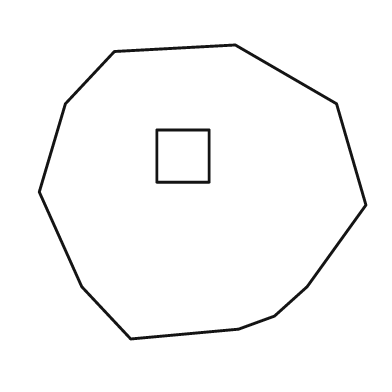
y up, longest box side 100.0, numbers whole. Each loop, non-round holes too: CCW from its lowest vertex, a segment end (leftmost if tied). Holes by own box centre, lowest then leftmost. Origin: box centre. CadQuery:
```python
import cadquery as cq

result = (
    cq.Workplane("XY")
    .moveTo(-22.0, -45.0)
    .lineTo(11.0, -42.0)
    .lineTo(22.0, -38.0)
    .lineTo(32.0, -29.0)
    .lineTo(50.0, -4.0)
    .lineTo(41.0, 27.0)
    .lineTo(10.0, 45.0)
    .lineTo(-27.0, 43.0)
    .lineTo(-42.0, 27.0)
    .lineTo(-50.0, 0.0)
    .lineTo(-37.0, -29.0)
    .close()
    .moveTo(-14.0, 3.0)
    .lineTo(2.0, 3.0)
    .lineTo(2.0, 19.0)
    .lineTo(-14.0, 19.0)
    .close()
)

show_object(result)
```